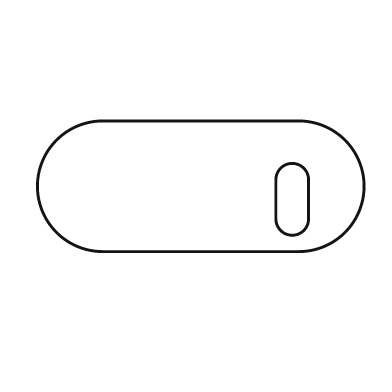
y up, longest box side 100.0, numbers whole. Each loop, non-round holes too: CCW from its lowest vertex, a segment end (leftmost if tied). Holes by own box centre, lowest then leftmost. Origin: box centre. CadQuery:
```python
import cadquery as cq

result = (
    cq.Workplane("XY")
    .moveTo(-30.0, -20.0)
    .lineTo(30.0, -20.0)
    .threePointArc((50.0, 0.0), (30.0, 20.0))
    .lineTo(-30.0, 20.0)
    .threePointArc((-50.0, 0.0), (-30.0, -20.0))
    .close()
    .moveTo(23.0, -10.0)
    .threePointArc((28.0, -15.0), (33.0, -10.0))
    .lineTo(33.0, 2.0)
    .threePointArc((28.0, 7.0), (23.0, 2.0))
    .close()
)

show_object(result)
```